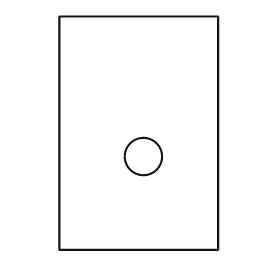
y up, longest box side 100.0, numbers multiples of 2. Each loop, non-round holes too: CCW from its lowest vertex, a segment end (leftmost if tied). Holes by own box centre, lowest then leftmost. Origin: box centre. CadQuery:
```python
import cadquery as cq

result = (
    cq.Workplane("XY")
    .moveTo(-34.0, -50.0)
    .lineTo(34.0, -50.0)
    .lineTo(34.0, 50.0)
    .lineTo(-34.0, 50.0)
    .close()
    .moveTo(2.0, -10.0)
    .circle(8.0)
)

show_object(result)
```